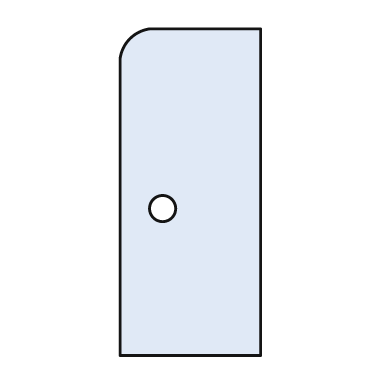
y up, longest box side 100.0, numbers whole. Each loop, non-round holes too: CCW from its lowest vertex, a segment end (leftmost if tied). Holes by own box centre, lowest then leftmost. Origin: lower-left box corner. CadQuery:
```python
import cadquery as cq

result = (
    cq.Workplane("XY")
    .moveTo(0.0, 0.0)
    .lineTo(43.0, 0.0)
    .lineTo(43.0, 100.0)
    .lineTo(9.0, 100.0)
    .threePointArc((3.0, 97.0), (0.0, 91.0))
    .close()
    .moveTo(13.0, 45.0)
    .circle(4.0)
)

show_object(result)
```